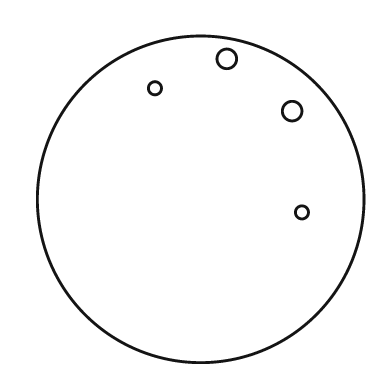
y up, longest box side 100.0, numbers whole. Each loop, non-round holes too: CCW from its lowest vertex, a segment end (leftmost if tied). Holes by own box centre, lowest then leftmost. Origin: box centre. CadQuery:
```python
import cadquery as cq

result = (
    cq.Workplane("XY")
    .moveTo(0.0, 0.0)
    .circle(50.0)
    .moveTo(31.0, -4.0)
    .circle(2.0)
    .moveTo(28.0, 27.0)
    .circle(3.0)
    .moveTo(-14.0, 34.0)
    .circle(2.0)
    .moveTo(8.0, 43.0)
    .circle(3.0)
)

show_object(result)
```